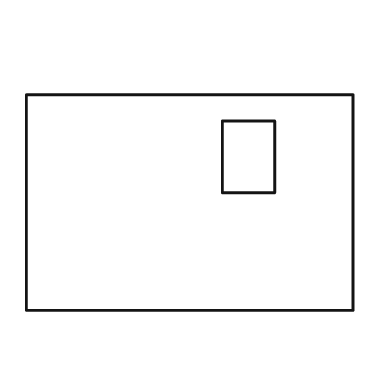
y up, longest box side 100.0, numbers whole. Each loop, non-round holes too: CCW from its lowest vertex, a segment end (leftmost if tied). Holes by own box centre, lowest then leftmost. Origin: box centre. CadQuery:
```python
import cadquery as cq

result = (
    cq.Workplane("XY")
    .moveTo(-50.0, -33.0)
    .lineTo(50.0, -33.0)
    .lineTo(50.0, 33.0)
    .lineTo(-50.0, 33.0)
    .close()
    .moveTo(10.0, 3.0)
    .lineTo(26.0, 3.0)
    .lineTo(26.0, 25.0)
    .lineTo(10.0, 25.0)
    .close()
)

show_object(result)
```